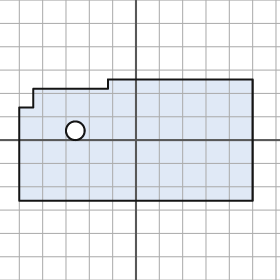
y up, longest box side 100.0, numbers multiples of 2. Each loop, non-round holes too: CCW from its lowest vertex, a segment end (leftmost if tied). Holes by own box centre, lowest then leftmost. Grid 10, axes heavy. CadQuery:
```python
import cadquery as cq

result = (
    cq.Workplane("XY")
    .moveTo(-50.0, -26.0)
    .lineTo(50.0, -26.0)
    .lineTo(50.0, 26.0)
    .lineTo(-12.0, 26.0)
    .lineTo(-12.0, 22.0)
    .lineTo(-44.0, 22.0)
    .lineTo(-44.0, 14.0)
    .lineTo(-50.0, 14.0)
    .close()
    .moveTo(-26.0, 4.0)
    .circle(4.0)
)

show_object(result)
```